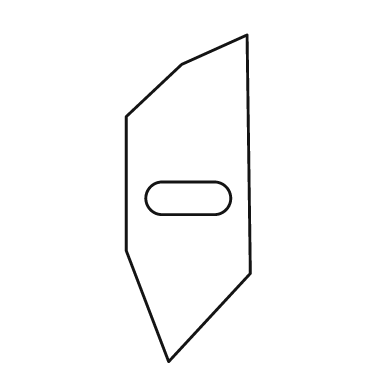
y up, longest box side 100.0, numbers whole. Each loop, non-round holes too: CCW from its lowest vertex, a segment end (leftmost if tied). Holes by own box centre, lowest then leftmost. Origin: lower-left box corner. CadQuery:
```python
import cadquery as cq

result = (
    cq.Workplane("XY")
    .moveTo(13.0, 0.0)
    .lineTo(38.0, 27.0)
    .lineTo(37.0, 100.0)
    .lineTo(17.0, 91.0)
    .lineTo(0.0, 75.0)
    .lineTo(0.0, 34.0)
    .close()
    .moveTo(11.0, 45.0)
    .lineTo(27.0, 45.0)
    .threePointArc((32.0, 50.0), (27.0, 55.0))
    .lineTo(11.0, 55.0)
    .threePointArc((6.0, 50.0), (11.0, 45.0))
    .close()
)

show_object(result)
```